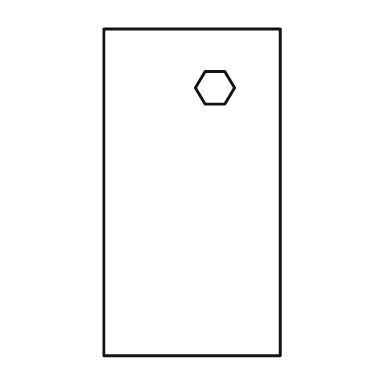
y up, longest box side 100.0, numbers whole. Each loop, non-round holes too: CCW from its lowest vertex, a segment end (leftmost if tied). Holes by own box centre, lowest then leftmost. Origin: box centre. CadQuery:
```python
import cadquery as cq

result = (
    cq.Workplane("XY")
    .moveTo(-27.0, -50.0)
    .lineTo(27.0, -50.0)
    .lineTo(27.0, 50.0)
    .lineTo(-27.0, 50.0)
    .close()
    .moveTo(4.0, 27.0)
    .lineTo(10.0, 27.0)
    .lineTo(13.0, 32.0)
    .lineTo(10.0, 37.0)
    .lineTo(4.0, 37.0)
    .lineTo(1.0, 32.0)
    .close()
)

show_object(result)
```